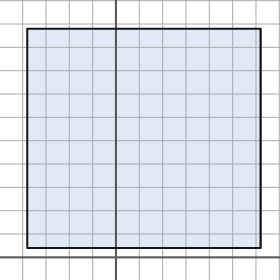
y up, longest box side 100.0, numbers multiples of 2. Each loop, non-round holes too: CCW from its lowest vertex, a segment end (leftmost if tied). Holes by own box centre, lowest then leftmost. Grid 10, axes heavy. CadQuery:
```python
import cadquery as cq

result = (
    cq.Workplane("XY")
    .moveTo(-38.0, 4.0)
    .lineTo(62.0, 4.0)
    .lineTo(62.0, 98.0)
    .lineTo(-38.0, 98.0)
    .close()
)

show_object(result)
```